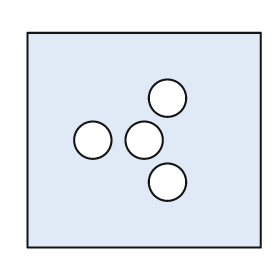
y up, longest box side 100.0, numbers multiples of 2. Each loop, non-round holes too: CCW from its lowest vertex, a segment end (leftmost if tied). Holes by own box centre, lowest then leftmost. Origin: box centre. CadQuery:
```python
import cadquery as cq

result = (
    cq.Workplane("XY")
    .moveTo(-50.0, -46.0)
    .lineTo(50.0, -46.0)
    .lineTo(50.0, 46.0)
    .lineTo(-50.0, 46.0)
    .close()
    .moveTo(10.0, -18.0)
    .circle(8.0)
    .moveTo(-22.0, 0.0)
    .circle(8.0)
    .moveTo(0.0, 0.0)
    .circle(8.0)
    .moveTo(10.0, 18.0)
    .circle(8.0)
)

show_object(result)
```